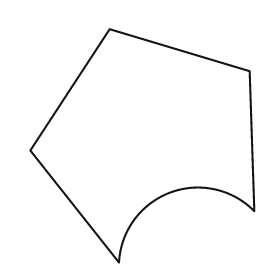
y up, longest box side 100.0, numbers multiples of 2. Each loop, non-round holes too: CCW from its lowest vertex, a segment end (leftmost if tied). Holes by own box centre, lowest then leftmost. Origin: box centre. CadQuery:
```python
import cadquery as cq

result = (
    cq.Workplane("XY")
    .moveTo(-10.0, -50.0)
    .threePointArc((12.0, -20.0), (48.0, -28.0))
    .lineTo(46.0, 32.0)
    .lineTo(-14.0, 50.0)
    .lineTo(-48.0, -2.0)
    .close()
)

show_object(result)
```